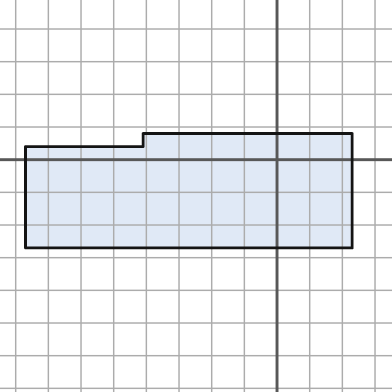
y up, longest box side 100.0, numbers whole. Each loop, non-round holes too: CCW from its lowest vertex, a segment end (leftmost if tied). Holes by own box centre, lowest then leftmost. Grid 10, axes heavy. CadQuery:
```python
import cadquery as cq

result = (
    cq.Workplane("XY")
    .moveTo(-77.0, -27.0)
    .lineTo(23.0, -27.0)
    .lineTo(23.0, 8.0)
    .lineTo(-41.0, 8.0)
    .lineTo(-41.0, 4.0)
    .lineTo(-77.0, 4.0)
    .close()
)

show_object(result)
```